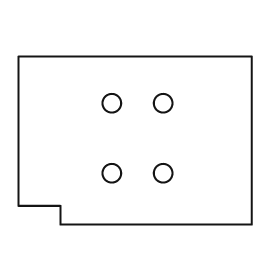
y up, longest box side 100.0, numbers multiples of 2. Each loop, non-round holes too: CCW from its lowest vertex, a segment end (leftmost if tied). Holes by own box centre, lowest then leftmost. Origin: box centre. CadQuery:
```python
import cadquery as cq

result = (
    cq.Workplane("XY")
    .moveTo(-32.0, -36.0)
    .lineTo(50.0, -36.0)
    .lineTo(50.0, 36.0)
    .lineTo(-50.0, 36.0)
    .lineTo(-50.0, -28.0)
    .lineTo(-32.0, -28.0)
    .close()
    .moveTo(-10.0, -14.0)
    .circle(4.0)
    .moveTo(12.0, -14.0)
    .circle(4.0)
    .moveTo(-10.0, 16.0)
    .circle(4.0)
    .moveTo(12.0, 16.0)
    .circle(4.0)
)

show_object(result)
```